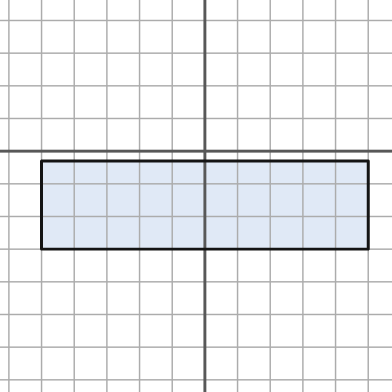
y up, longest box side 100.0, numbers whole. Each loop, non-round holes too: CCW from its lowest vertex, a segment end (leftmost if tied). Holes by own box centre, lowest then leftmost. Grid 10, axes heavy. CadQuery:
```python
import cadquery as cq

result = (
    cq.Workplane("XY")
    .moveTo(-50.0, -30.0)
    .lineTo(50.0, -30.0)
    .lineTo(50.0, -3.0)
    .lineTo(-50.0, -3.0)
    .close()
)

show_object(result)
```